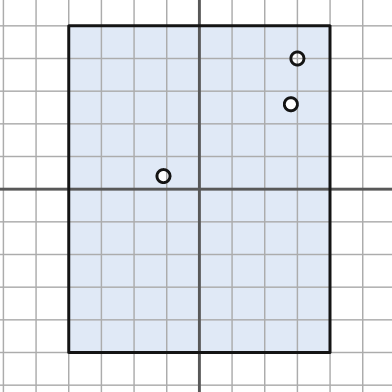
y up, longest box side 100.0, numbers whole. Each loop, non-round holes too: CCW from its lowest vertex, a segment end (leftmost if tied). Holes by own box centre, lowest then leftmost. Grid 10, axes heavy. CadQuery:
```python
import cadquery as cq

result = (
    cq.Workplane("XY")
    .moveTo(-40.0, -50.0)
    .lineTo(40.0, -50.0)
    .lineTo(40.0, 50.0)
    .lineTo(-40.0, 50.0)
    .close()
    .moveTo(-11.0, 4.0)
    .circle(2.0)
    .moveTo(28.0, 26.0)
    .circle(2.0)
    .moveTo(30.0, 40.0)
    .circle(2.0)
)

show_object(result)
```